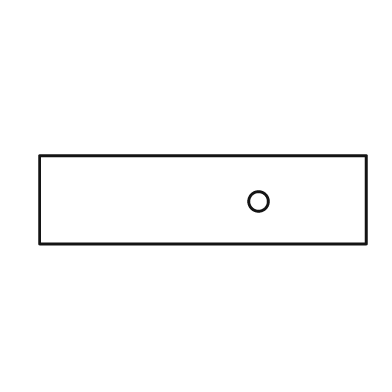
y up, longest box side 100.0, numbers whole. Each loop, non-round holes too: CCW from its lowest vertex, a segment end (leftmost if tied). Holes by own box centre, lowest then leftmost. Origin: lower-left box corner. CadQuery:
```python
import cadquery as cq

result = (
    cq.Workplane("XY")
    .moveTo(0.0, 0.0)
    .lineTo(100.0, 0.0)
    .lineTo(100.0, 27.0)
    .lineTo(0.0, 27.0)
    .close()
    .moveTo(67.0, 13.0)
    .circle(3.0)
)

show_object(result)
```